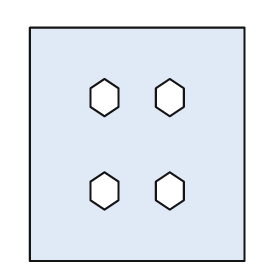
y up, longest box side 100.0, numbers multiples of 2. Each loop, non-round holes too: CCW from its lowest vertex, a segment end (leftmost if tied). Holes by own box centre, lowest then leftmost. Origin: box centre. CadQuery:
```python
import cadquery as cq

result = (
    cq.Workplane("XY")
    .moveTo(-46.0, -50.0)
    .lineTo(46.0, -50.0)
    .lineTo(46.0, 50.0)
    .lineTo(-46.0, 50.0)
    .close()
    .moveTo(-14.0, -28.0)
    .lineTo(-8.0, -24.0)
    .lineTo(-8.0, -16.0)
    .lineTo(-14.0, -12.0)
    .lineTo(-20.0, -16.0)
    .lineTo(-20.0, -24.0)
    .close()
    .moveTo(14.0, -28.0)
    .lineTo(20.0, -24.0)
    .lineTo(20.0, -16.0)
    .lineTo(14.0, -12.0)
    .lineTo(8.0, -16.0)
    .lineTo(8.0, -24.0)
    .close()
    .moveTo(-14.0, 12.0)
    .lineTo(-8.0, 16.0)
    .lineTo(-8.0, 24.0)
    .lineTo(-14.0, 28.0)
    .lineTo(-20.0, 24.0)
    .lineTo(-20.0, 16.0)
    .close()
    .moveTo(14.0, 12.0)
    .lineTo(20.0, 16.0)
    .lineTo(20.0, 24.0)
    .lineTo(14.0, 28.0)
    .lineTo(8.0, 24.0)
    .lineTo(8.0, 16.0)
    .close()
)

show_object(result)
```